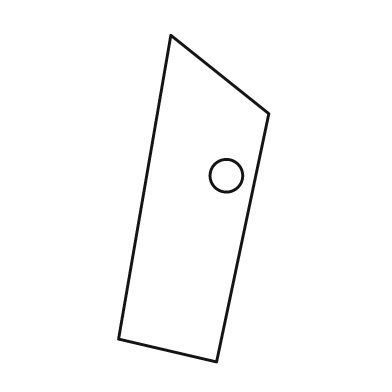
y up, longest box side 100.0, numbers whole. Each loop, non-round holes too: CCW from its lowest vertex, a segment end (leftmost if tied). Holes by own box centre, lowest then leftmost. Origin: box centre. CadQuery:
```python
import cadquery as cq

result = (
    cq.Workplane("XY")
    .moveTo(7.0, -50.0)
    .lineTo(23.0, 26.0)
    .lineTo(-7.0, 50.0)
    .lineTo(-23.0, -43.0)
    .close()
    .moveTo(10.0, 7.0)
    .circle(5.0)
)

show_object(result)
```